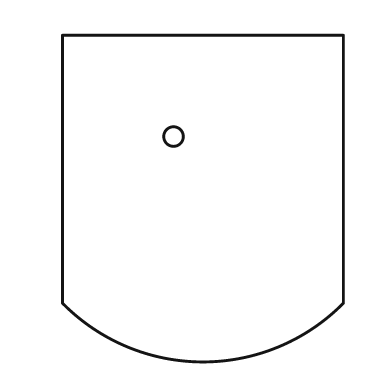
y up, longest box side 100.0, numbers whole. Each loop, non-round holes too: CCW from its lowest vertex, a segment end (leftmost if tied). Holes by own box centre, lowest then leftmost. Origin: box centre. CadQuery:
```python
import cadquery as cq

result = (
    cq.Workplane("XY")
    .moveTo(-43.0, -32.0)
    .threePointArc((0.0, -50.0), (43.0, -32.0))
    .lineTo(43.0, 50.0)
    .lineTo(-43.0, 50.0)
    .close()
    .moveTo(-9.0, 19.0)
    .circle(3.0)
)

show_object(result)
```